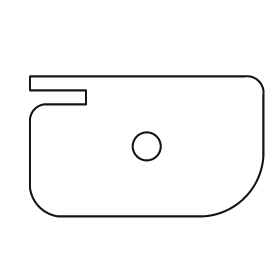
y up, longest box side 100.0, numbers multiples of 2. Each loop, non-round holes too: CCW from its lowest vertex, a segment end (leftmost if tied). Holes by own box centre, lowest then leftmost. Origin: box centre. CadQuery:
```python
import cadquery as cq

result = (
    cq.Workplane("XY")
    .moveTo(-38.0, -30.0)
    .lineTo(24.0, -30.0)
    .threePointArc((42.0, -22.0), (50.0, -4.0))
    .lineTo(50.0, 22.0)
    .threePointArc((48.0, 28.0), (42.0, 30.0))
    .lineTo(-50.0, 30.0)
    .lineTo(-50.0, 24.0)
    .lineTo(-26.0, 24.0)
    .lineTo(-26.0, 18.0)
    .lineTo(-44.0, 18.0)
    .threePointArc((-48.0, 16.0), (-50.0, 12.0))
    .lineTo(-50.0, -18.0)
    .threePointArc((-46.0, -26.0), (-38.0, -30.0))
    .close()
    .moveTo(0.0, 0.0)
    .circle(6.0)
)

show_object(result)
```